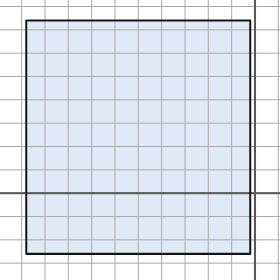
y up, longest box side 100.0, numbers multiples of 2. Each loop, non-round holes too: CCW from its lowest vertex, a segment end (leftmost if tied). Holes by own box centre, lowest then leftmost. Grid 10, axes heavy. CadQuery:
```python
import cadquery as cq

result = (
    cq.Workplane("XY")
    .moveTo(-98.0, -26.0)
    .lineTo(-2.0, -26.0)
    .lineTo(-2.0, 74.0)
    .lineTo(-98.0, 74.0)
    .close()
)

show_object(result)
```